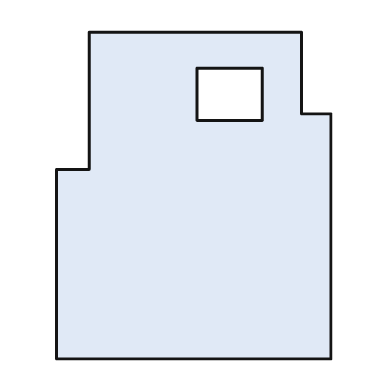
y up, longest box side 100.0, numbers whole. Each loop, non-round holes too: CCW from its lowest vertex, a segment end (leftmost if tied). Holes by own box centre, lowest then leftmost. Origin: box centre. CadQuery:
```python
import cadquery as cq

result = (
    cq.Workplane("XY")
    .moveTo(-42.0, -50.0)
    .lineTo(42.0, -50.0)
    .lineTo(42.0, 25.0)
    .lineTo(33.0, 25.0)
    .lineTo(33.0, 50.0)
    .lineTo(-32.0, 50.0)
    .lineTo(-32.0, 8.0)
    .lineTo(-42.0, 8.0)
    .close()
    .moveTo(1.0, 23.0)
    .lineTo(21.0, 23.0)
    .lineTo(21.0, 39.0)
    .lineTo(1.0, 39.0)
    .close()
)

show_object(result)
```